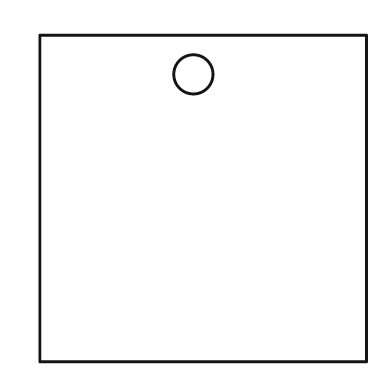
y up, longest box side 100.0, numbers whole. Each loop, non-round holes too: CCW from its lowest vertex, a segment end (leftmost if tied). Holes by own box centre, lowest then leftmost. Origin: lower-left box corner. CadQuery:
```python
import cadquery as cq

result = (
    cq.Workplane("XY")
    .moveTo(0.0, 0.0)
    .lineTo(100.0, 0.0)
    .lineTo(100.0, 100.0)
    .lineTo(0.0, 100.0)
    .close()
    .moveTo(47.0, 88.0)
    .circle(6.0)
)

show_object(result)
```